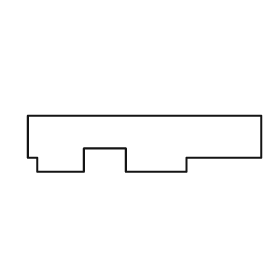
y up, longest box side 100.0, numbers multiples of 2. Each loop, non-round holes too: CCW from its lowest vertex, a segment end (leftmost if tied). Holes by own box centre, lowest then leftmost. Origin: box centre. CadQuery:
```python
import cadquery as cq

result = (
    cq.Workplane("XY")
    .moveTo(-46.0, -12.0)
    .lineTo(-26.0, -12.0)
    .lineTo(-26.0, -2.0)
    .lineTo(-8.0, -2.0)
    .lineTo(-8.0, -12.0)
    .lineTo(18.0, -12.0)
    .lineTo(18.0, -6.0)
    .lineTo(50.0, -6.0)
    .lineTo(50.0, 12.0)
    .lineTo(-50.0, 12.0)
    .lineTo(-50.0, -6.0)
    .lineTo(-46.0, -6.0)
    .close()
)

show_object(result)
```